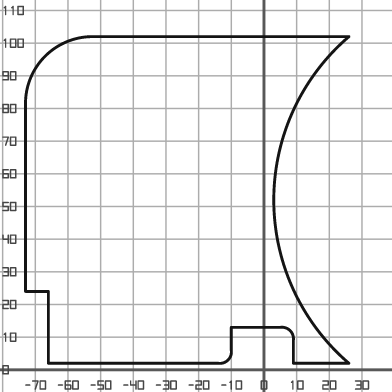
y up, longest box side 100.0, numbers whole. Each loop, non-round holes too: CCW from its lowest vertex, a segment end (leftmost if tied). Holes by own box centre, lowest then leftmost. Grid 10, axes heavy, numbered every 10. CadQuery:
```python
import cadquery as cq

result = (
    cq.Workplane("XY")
    .moveTo(-66.0, 2.0)
    .lineTo(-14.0, 2.0)
    .threePointArc((-11.0, 3.0), (-10.0, 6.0))
    .lineTo(-10.0, 13.0)
    .lineTo(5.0, 13.0)
    .threePointArc((8.0, 12.0), (9.0, 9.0))
    .lineTo(9.0, 2.0)
    .lineTo(26.0, 2.0)
    .threePointArc((3.0, 52.0), (26.0, 102.0))
    .lineTo(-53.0, 102.0)
    .threePointArc((-67.0, 96.0), (-73.0, 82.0))
    .lineTo(-73.0, 24.0)
    .lineTo(-66.0, 24.0)
    .close()
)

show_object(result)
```